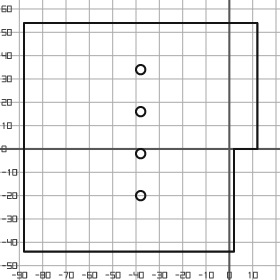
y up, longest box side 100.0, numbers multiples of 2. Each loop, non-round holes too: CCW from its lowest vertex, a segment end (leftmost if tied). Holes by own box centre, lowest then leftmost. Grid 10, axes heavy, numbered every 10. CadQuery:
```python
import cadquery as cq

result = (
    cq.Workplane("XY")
    .moveTo(-88.0, -44.0)
    .lineTo(2.0, -44.0)
    .lineTo(2.0, 0.0)
    .lineTo(12.0, 0.0)
    .lineTo(12.0, 54.0)
    .lineTo(-88.0, 54.0)
    .close()
    .moveTo(-38.0, -20.0)
    .circle(2.0)
    .moveTo(-38.0, -2.0)
    .circle(2.0)
    .moveTo(-38.0, 16.0)
    .circle(2.0)
    .moveTo(-38.0, 34.0)
    .circle(2.0)
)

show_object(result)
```